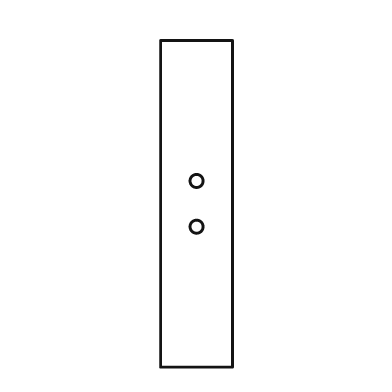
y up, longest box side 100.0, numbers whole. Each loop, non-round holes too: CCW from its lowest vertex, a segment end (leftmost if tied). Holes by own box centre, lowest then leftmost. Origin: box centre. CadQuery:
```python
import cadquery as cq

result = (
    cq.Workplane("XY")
    .moveTo(-11.0, -50.0)
    .lineTo(11.0, -50.0)
    .lineTo(11.0, 50.0)
    .lineTo(-11.0, 50.0)
    .close()
    .moveTo(0.0, -7.0)
    .circle(2.0)
    .moveTo(0.0, 7.0)
    .circle(2.0)
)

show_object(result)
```